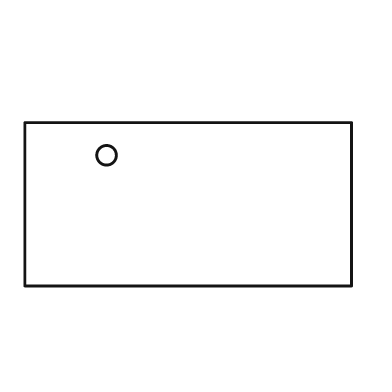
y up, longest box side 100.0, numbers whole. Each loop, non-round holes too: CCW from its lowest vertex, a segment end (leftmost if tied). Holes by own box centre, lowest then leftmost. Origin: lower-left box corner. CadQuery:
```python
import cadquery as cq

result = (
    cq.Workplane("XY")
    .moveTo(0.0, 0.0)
    .lineTo(100.0, 0.0)
    .lineTo(100.0, 50.0)
    .lineTo(0.0, 50.0)
    .close()
    .moveTo(25.0, 40.0)
    .circle(3.0)
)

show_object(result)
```